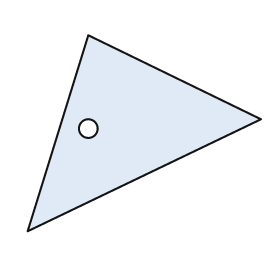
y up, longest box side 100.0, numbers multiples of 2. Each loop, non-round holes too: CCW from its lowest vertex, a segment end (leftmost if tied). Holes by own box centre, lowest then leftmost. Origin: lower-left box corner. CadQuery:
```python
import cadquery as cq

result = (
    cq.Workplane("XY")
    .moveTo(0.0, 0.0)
    .lineTo(100.0, 48.0)
    .lineTo(26.0, 84.0)
    .close()
    .moveTo(26.0, 44.0)
    .circle(4.0)
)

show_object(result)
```